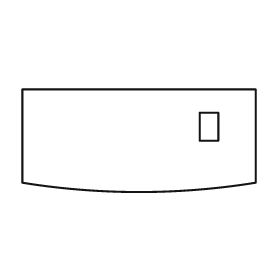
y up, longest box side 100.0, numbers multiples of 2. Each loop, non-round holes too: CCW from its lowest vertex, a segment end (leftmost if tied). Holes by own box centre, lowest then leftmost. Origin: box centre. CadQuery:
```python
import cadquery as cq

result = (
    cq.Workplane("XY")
    .moveTo(-50.0, -18.0)
    .threePointArc((0.0, -22.0), (50.0, -18.0))
    .lineTo(50.0, 22.0)
    .lineTo(-50.0, 22.0)
    .close()
    .moveTo(26.0, 0.0)
    .lineTo(34.0, 0.0)
    .lineTo(34.0, 12.0)
    .lineTo(26.0, 12.0)
    .close()
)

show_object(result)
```